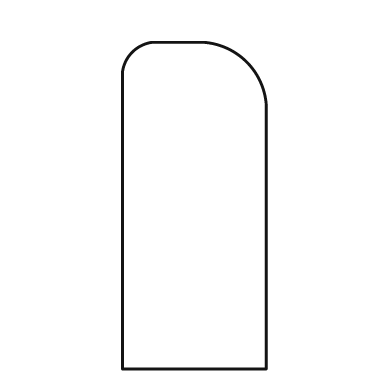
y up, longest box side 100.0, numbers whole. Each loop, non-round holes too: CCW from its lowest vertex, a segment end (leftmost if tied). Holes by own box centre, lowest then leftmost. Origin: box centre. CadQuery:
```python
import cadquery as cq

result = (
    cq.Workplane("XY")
    .moveTo(-22.0, -50.0)
    .lineTo(22.0, -50.0)
    .lineTo(22.0, 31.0)
    .threePointArc((16.0, 44.0), (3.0, 50.0))
    .lineTo(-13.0, 50.0)
    .threePointArc((-19.0, 47.0), (-22.0, 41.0))
    .close()
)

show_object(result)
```